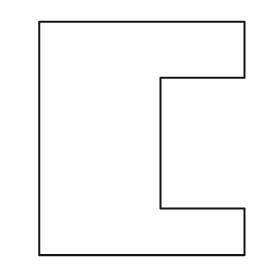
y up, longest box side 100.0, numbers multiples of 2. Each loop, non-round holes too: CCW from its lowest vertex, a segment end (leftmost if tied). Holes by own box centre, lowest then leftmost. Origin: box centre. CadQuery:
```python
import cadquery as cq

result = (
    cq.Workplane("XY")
    .moveTo(-44.0, -50.0)
    .lineTo(44.0, -50.0)
    .lineTo(44.0, -30.0)
    .lineTo(8.0, -30.0)
    .lineTo(8.0, 26.0)
    .lineTo(44.0, 26.0)
    .lineTo(44.0, 50.0)
    .lineTo(-44.0, 50.0)
    .close()
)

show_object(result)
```